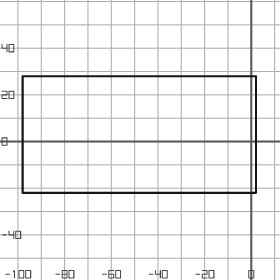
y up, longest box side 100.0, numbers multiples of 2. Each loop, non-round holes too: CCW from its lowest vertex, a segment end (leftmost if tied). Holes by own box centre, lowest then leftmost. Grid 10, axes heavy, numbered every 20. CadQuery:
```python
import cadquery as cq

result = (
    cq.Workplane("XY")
    .moveTo(-98.0, -22.0)
    .lineTo(2.0, -22.0)
    .lineTo(2.0, 28.0)
    .lineTo(-98.0, 28.0)
    .close()
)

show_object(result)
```